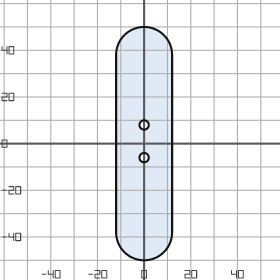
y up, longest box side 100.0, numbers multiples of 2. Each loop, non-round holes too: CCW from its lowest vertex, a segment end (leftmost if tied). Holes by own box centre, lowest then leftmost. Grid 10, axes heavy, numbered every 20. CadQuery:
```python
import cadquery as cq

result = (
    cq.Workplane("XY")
    .moveTo(-12.0, -38.0)
    .threePointArc((0.0, -50.0), (12.0, -38.0))
    .lineTo(12.0, 38.0)
    .threePointArc((0.0, 50.0), (-12.0, 38.0))
    .close()
    .moveTo(0.0, -6.0)
    .circle(2.0)
    .moveTo(0.0, 8.0)
    .circle(2.0)
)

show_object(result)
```